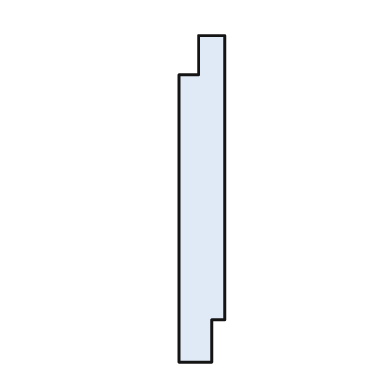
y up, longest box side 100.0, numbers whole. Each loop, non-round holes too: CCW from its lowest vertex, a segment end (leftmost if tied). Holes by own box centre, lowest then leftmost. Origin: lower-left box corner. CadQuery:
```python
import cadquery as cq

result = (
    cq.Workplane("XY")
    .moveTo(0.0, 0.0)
    .lineTo(10.0, 0.0)
    .lineTo(10.0, 13.0)
    .lineTo(14.0, 13.0)
    .lineTo(14.0, 100.0)
    .lineTo(6.0, 100.0)
    .lineTo(6.0, 88.0)
    .lineTo(0.0, 88.0)
    .close()
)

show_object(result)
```